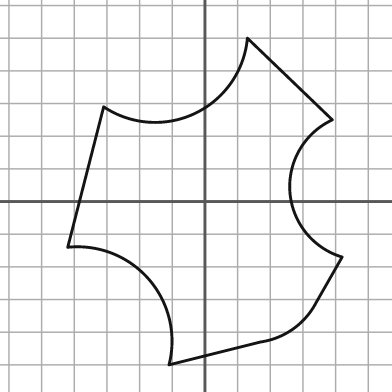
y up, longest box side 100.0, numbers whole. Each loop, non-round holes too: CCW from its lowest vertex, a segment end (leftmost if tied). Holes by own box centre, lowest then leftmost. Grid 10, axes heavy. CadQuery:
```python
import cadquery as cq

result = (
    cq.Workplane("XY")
    .moveTo(-11.0, -50.0)
    .lineTo(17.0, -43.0)
    .threePointArc((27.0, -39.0), (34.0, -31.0))
    .lineTo(42.0, -17.0)
    .threePointArc((26.0, 3.0), (39.0, 25.0))
    .lineTo(13.0, 50.0)
    .threePointArc((-3.0, 27.0), (-31.0, 29.0))
    .lineTo(-42.0, -14.0)
    .threePointArc((-17.0, -24.0), (-11.0, -50.0))
    .close()
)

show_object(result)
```